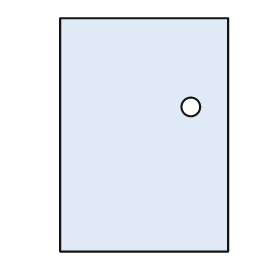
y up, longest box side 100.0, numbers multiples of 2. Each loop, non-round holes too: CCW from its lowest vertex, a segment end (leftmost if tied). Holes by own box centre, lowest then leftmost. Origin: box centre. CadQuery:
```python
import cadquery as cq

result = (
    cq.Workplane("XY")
    .moveTo(-36.0, -50.0)
    .lineTo(36.0, -50.0)
    .lineTo(36.0, 50.0)
    .lineTo(-36.0, 50.0)
    .close()
    .moveTo(20.0, 12.0)
    .circle(4.0)
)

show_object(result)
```